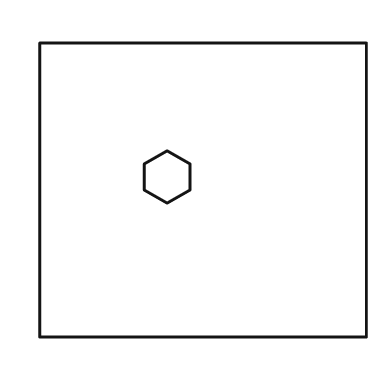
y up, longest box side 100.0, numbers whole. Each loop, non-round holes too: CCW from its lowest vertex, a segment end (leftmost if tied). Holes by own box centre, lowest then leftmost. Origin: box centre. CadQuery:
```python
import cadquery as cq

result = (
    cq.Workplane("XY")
    .moveTo(-50.0, -45.0)
    .lineTo(50.0, -45.0)
    .lineTo(50.0, 45.0)
    .lineTo(-50.0, 45.0)
    .close()
    .moveTo(-11.0, -4.0)
    .lineTo(-4.0, 0.0)
    .lineTo(-4.0, 8.0)
    .lineTo(-11.0, 12.0)
    .lineTo(-18.0, 8.0)
    .lineTo(-18.0, 0.0)
    .close()
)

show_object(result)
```